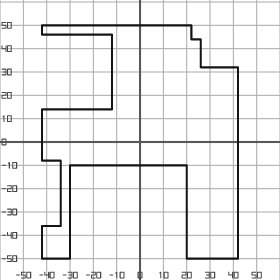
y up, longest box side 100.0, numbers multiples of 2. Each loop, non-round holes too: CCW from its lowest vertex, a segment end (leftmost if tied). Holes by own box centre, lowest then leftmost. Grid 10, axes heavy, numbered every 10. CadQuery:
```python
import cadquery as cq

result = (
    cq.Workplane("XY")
    .moveTo(-42.0, -50.0)
    .lineTo(-30.0, -50.0)
    .lineTo(-30.0, -10.0)
    .lineTo(20.0, -10.0)
    .lineTo(20.0, -50.0)
    .lineTo(42.0, -50.0)
    .lineTo(42.0, 32.0)
    .lineTo(26.0, 32.0)
    .lineTo(26.0, 44.0)
    .lineTo(22.0, 44.0)
    .lineTo(22.0, 50.0)
    .lineTo(-42.0, 50.0)
    .lineTo(-42.0, 46.0)
    .lineTo(-12.0, 46.0)
    .lineTo(-12.0, 14.0)
    .lineTo(-42.0, 14.0)
    .lineTo(-42.0, -8.0)
    .lineTo(-34.0, -8.0)
    .lineTo(-34.0, -36.0)
    .lineTo(-42.0, -36.0)
    .close()
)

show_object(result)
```